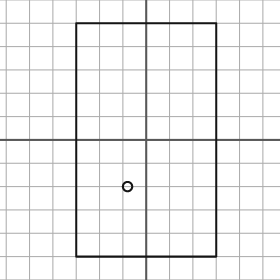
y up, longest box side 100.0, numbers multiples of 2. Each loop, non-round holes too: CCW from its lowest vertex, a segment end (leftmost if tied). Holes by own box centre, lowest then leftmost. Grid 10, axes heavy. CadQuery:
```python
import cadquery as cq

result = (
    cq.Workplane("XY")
    .moveTo(-30.0, -50.0)
    .lineTo(30.0, -50.0)
    .lineTo(30.0, 50.0)
    .lineTo(-30.0, 50.0)
    .close()
    .moveTo(-8.0, -20.0)
    .circle(2.0)
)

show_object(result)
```